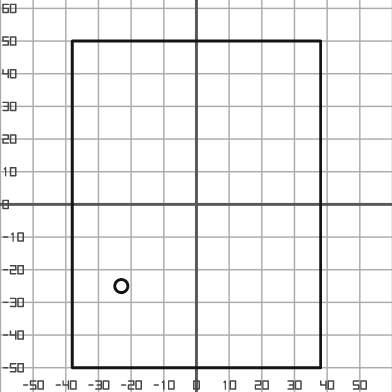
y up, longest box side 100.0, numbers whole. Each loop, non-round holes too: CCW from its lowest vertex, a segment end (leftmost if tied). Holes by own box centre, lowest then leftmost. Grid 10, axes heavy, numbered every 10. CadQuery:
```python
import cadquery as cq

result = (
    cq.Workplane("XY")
    .moveTo(-38.0, -50.0)
    .lineTo(38.0, -50.0)
    .lineTo(38.0, 50.0)
    .lineTo(-38.0, 50.0)
    .close()
    .moveTo(-23.0, -25.0)
    .circle(2.0)
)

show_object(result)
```